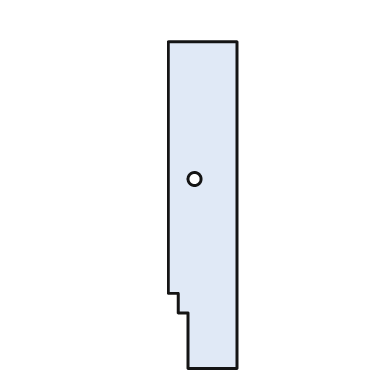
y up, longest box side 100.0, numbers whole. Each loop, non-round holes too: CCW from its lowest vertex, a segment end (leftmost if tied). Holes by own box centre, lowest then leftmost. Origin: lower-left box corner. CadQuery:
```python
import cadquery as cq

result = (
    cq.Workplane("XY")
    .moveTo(6.0, 0.0)
    .lineTo(21.0, 0.0)
    .lineTo(21.0, 100.0)
    .lineTo(0.0, 100.0)
    .lineTo(0.0, 23.0)
    .lineTo(3.0, 23.0)
    .lineTo(3.0, 17.0)
    .lineTo(6.0, 17.0)
    .close()
    .moveTo(8.0, 58.0)
    .circle(2.0)
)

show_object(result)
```